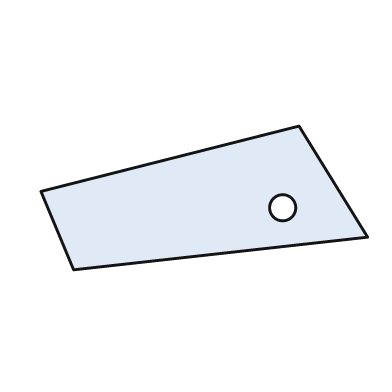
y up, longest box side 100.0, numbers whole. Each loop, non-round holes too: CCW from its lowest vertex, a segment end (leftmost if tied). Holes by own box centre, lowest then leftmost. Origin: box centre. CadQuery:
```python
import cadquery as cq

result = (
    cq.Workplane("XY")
    .moveTo(-40.0, -22.0)
    .lineTo(50.0, -12.0)
    .lineTo(29.0, 22.0)
    .lineTo(-50.0, 2.0)
    .close()
    .moveTo(24.0, -3.0)
    .circle(4.0)
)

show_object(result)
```